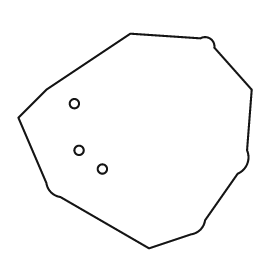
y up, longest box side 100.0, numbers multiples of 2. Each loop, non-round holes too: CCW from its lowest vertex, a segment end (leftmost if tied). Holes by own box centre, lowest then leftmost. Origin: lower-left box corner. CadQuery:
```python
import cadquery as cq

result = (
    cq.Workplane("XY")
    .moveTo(56.0, 0.0)
    .lineTo(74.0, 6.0)
    .threePointArc((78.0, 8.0), (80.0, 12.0))
    .lineTo(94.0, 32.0)
    .threePointArc((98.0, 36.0), (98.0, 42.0))
    .lineTo(100.0, 68.0)
    .lineTo(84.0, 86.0)
    .threePointArc((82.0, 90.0), (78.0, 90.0))
    .lineTo(48.0, 92.0)
    .lineTo(12.0, 68.0)
    .lineTo(0.0, 56.0)
    .lineTo(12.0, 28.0)
    .threePointArc((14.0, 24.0), (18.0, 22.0))
    .close()
    .moveTo(36.0, 34.0)
    .circle(2.0)
    .moveTo(26.0, 42.0)
    .circle(2.0)
    .moveTo(24.0, 62.0)
    .circle(2.0)
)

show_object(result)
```